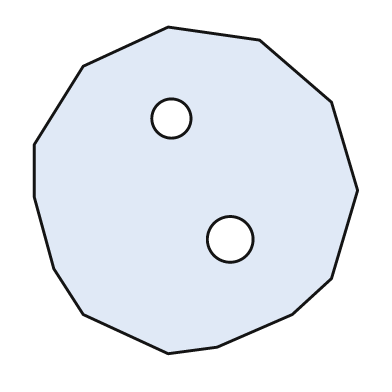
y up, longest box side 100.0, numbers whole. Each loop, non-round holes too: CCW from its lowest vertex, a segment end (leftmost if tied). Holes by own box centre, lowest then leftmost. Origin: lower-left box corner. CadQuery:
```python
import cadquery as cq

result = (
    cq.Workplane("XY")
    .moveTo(41.0, 0.0)
    .lineTo(56.0, 2.0)
    .lineTo(79.0, 12.0)
    .lineTo(91.0, 23.0)
    .lineTo(99.0, 50.0)
    .lineTo(91.0, 77.0)
    .lineTo(69.0, 96.0)
    .lineTo(41.0, 100.0)
    .lineTo(15.0, 88.0)
    .lineTo(0.0, 64.0)
    .lineTo(0.0, 48.0)
    .lineTo(6.0, 26.0)
    .lineTo(15.0, 12.0)
    .close()
    .moveTo(60.0, 35.0)
    .circle(7.0)
    .moveTo(42.0, 72.0)
    .circle(6.0)
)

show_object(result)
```